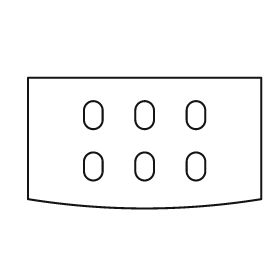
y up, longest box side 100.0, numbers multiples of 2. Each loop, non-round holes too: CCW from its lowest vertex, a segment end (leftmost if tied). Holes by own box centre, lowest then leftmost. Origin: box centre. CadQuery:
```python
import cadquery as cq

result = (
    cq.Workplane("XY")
    .moveTo(-50.0, -24.0)
    .threePointArc((0.0, -28.0), (50.0, -24.0))
    .lineTo(50.0, 28.0)
    .lineTo(-50.0, 28.0)
    .close()
    .moveTo(-26.0, -12.0)
    .threePointArc((-22.0, -16.0), (-18.0, -12.0))
    .lineTo(-18.0, -8.0)
    .threePointArc((-22.0, -4.0), (-26.0, -8.0))
    .close()
    .moveTo(-4.0, -12.0)
    .threePointArc((0.0, -16.0), (4.0, -12.0))
    .lineTo(4.0, -8.0)
    .threePointArc((0.0, -4.0), (-4.0, -8.0))
    .close()
    .moveTo(18.0, -12.0)
    .threePointArc((22.0, -16.0), (26.0, -12.0))
    .lineTo(26.0, -8.0)
    .threePointArc((22.0, -4.0), (18.0, -8.0))
    .close()
    .moveTo(-26.0, 10.0)
    .threePointArc((-22.0, 6.0), (-18.0, 10.0))
    .lineTo(-18.0, 14.0)
    .threePointArc((-22.0, 18.0), (-26.0, 14.0))
    .close()
    .moveTo(-4.0, 10.0)
    .threePointArc((0.0, 6.0), (4.0, 10.0))
    .lineTo(4.0, 14.0)
    .threePointArc((0.0, 18.0), (-4.0, 14.0))
    .close()
    .moveTo(18.0, 10.0)
    .threePointArc((22.0, 6.0), (26.0, 10.0))
    .lineTo(26.0, 14.0)
    .threePointArc((22.0, 18.0), (18.0, 14.0))
    .close()
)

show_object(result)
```